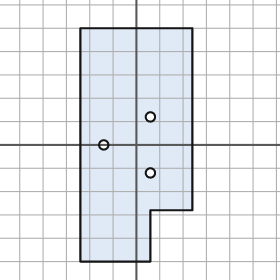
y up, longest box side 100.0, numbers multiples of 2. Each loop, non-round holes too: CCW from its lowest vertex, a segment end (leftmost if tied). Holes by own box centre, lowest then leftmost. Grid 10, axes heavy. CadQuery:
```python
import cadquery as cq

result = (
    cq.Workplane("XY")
    .moveTo(-24.0, -50.0)
    .lineTo(6.0, -50.0)
    .lineTo(6.0, -28.0)
    .lineTo(24.0, -28.0)
    .lineTo(24.0, 50.0)
    .lineTo(-24.0, 50.0)
    .close()
    .moveTo(6.0, -12.0)
    .circle(2.0)
    .moveTo(-14.0, 0.0)
    .circle(2.0)
    .moveTo(6.0, 12.0)
    .circle(2.0)
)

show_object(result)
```